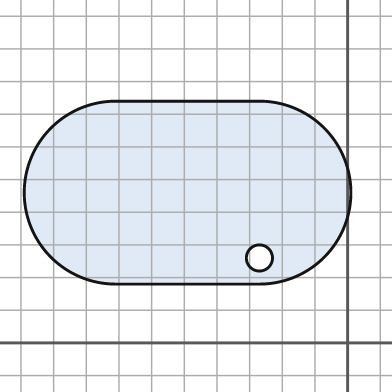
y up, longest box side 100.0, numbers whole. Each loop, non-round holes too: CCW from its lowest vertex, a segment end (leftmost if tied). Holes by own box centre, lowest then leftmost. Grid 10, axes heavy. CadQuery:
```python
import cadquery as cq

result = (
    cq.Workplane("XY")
    .moveTo(-71.0, 18.0)
    .lineTo(-27.0, 18.0)
    .threePointArc((1.0, 46.0), (-27.0, 74.0))
    .lineTo(-71.0, 74.0)
    .threePointArc((-99.0, 46.0), (-71.0, 18.0))
    .close()
    .moveTo(-27.0, 26.0)
    .circle(4.0)
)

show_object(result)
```